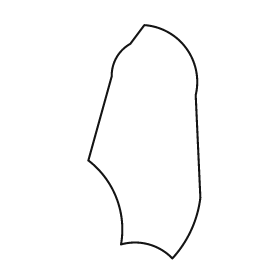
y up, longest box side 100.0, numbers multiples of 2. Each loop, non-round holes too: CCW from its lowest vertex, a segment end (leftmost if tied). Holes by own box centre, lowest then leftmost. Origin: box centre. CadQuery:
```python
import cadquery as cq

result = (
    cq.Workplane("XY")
    .moveTo(12.0, -50.0)
    .threePointArc((20.0, -38.0), (24.0, -24.0))
    .lineTo(22.0, 20.0)
    .threePointArc((18.0, 40.0), (0.0, 50.0))
    .lineTo(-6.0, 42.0)
    .threePointArc((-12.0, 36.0), (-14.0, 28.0))
    .lineTo(-24.0, -8.0)
    .threePointArc((-12.0, -24.0), (-10.0, -44.0))
    .threePointArc((2.0, -44.0), (12.0, -50.0))
    .close()
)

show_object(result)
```